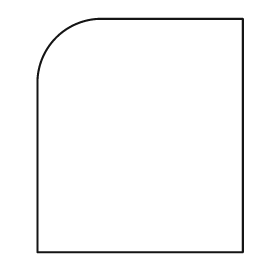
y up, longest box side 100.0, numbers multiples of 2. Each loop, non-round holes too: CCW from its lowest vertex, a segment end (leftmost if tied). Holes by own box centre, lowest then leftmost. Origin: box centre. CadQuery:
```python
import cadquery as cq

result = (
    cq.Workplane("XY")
    .moveTo(-44.0, -50.0)
    .lineTo(44.0, -50.0)
    .lineTo(44.0, 50.0)
    .lineTo(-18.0, 50.0)
    .threePointArc((-36.0, 42.0), (-44.0, 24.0))
    .close()
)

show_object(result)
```